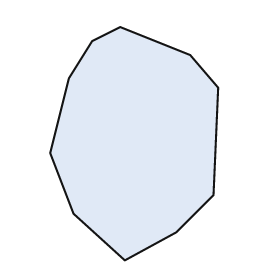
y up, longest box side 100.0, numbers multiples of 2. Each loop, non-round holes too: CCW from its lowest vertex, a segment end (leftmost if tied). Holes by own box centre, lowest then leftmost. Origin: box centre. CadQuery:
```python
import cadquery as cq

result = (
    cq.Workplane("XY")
    .moveTo(-4.0, -50.0)
    .lineTo(18.0, -38.0)
    .lineTo(34.0, -22.0)
    .lineTo(36.0, 24.0)
    .lineTo(24.0, 38.0)
    .lineTo(-6.0, 50.0)
    .lineTo(-18.0, 44.0)
    .lineTo(-28.0, 28.0)
    .lineTo(-36.0, -4.0)
    .lineTo(-26.0, -30.0)
    .close()
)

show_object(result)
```